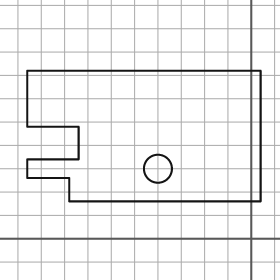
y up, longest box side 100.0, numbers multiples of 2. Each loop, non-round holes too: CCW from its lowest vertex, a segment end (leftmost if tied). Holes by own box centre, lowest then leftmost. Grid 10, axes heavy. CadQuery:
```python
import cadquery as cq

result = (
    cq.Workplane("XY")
    .moveTo(-78.0, 16.0)
    .lineTo(4.0, 16.0)
    .lineTo(4.0, 72.0)
    .lineTo(-96.0, 72.0)
    .lineTo(-96.0, 48.0)
    .lineTo(-74.0, 48.0)
    .lineTo(-74.0, 34.0)
    .lineTo(-96.0, 34.0)
    .lineTo(-96.0, 26.0)
    .lineTo(-78.0, 26.0)
    .close()
    .moveTo(-40.0, 30.0)
    .circle(6.0)
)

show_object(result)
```